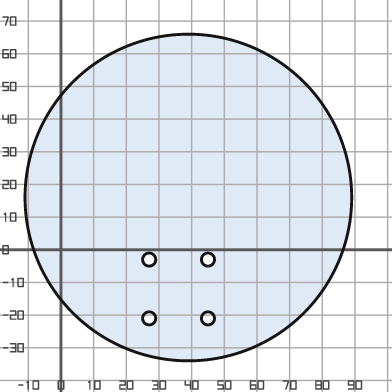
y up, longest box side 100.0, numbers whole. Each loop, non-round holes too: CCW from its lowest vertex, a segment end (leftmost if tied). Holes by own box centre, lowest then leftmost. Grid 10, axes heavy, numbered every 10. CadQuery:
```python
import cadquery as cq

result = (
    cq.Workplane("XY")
    .moveTo(39.0, 16.0)
    .circle(50.0)
    .moveTo(27.0, -21.0)
    .circle(2.0)
    .moveTo(45.0, -21.0)
    .circle(2.0)
    .moveTo(27.0, -3.0)
    .circle(2.0)
    .moveTo(45.0, -3.0)
    .circle(2.0)
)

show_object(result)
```